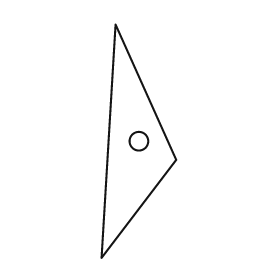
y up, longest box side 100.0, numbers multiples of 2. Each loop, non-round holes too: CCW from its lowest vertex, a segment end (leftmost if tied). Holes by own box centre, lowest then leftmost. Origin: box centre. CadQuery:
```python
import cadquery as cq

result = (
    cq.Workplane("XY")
    .moveTo(-16.0, -50.0)
    .lineTo(16.0, -8.0)
    .lineTo(-10.0, 50.0)
    .close()
    .moveTo(0.0, 0.0)
    .circle(4.0)
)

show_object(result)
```